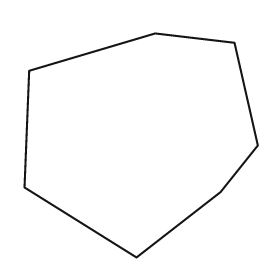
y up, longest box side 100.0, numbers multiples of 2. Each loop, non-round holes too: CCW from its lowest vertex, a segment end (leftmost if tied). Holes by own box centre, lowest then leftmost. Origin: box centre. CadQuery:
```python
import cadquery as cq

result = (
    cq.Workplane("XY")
    .moveTo(-2.0, -48.0)
    .lineTo(34.0, -20.0)
    .lineTo(50.0, 0.0)
    .lineTo(40.0, 44.0)
    .lineTo(6.0, 48.0)
    .lineTo(-48.0, 32.0)
    .lineTo(-50.0, -18.0)
    .close()
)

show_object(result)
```